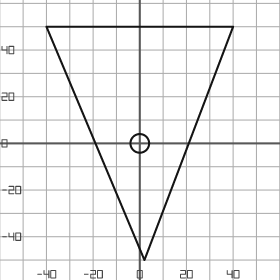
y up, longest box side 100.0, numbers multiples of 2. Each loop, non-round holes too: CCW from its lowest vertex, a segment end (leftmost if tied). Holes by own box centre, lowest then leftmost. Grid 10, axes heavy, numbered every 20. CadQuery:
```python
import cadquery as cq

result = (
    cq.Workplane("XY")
    .moveTo(2.0, -50.0)
    .lineTo(40.0, 50.0)
    .lineTo(-40.0, 50.0)
    .close()
    .moveTo(0.0, 0.0)
    .circle(4.0)
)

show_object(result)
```